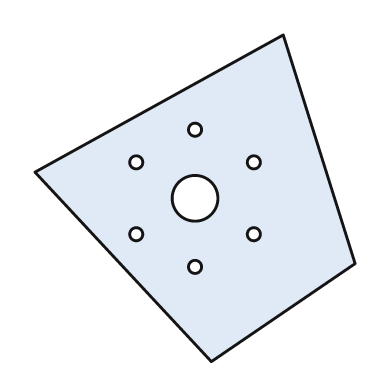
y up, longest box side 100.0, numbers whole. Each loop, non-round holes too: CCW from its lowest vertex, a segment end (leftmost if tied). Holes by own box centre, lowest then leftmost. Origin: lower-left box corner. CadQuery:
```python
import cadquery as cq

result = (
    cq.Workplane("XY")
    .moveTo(54.0, 0.0)
    .lineTo(98.0, 30.0)
    .lineTo(76.0, 100.0)
    .lineTo(0.0, 58.0)
    .close()
    .moveTo(49.0, 29.0)
    .circle(2.0)
    .moveTo(31.0, 39.0)
    .circle(2.0)
    .moveTo(67.0, 39.0)
    .circle(2.0)
    .moveTo(49.0, 50.0)
    .circle(7.0)
    .moveTo(31.0, 61.0)
    .circle(2.0)
    .moveTo(67.0, 61.0)
    .circle(2.0)
    .moveTo(49.0, 71.0)
    .circle(2.0)
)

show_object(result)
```